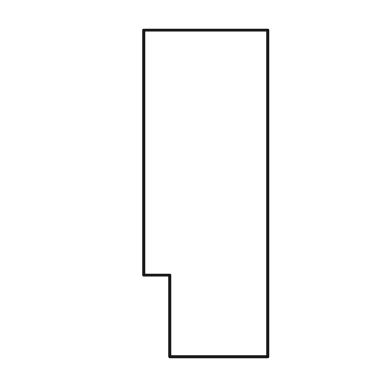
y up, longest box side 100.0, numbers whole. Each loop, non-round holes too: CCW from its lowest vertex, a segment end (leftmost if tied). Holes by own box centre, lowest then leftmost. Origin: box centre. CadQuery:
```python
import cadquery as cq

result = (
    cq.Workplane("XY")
    .moveTo(-11.0, -50.0)
    .lineTo(19.0, -50.0)
    .lineTo(19.0, 50.0)
    .lineTo(-19.0, 50.0)
    .lineTo(-19.0, -25.0)
    .lineTo(-11.0, -25.0)
    .close()
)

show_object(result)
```